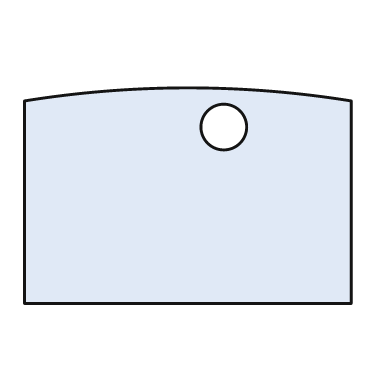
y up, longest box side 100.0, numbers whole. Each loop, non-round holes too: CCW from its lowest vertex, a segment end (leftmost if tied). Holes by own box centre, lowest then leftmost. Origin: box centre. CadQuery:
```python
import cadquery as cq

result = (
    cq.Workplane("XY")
    .moveTo(-50.0, -33.0)
    .lineTo(50.0, -33.0)
    .lineTo(50.0, 29.0)
    .threePointArc((0.0, 33.0), (-50.0, 29.0))
    .close()
    .moveTo(11.0, 21.0)
    .circle(7.0)
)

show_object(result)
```